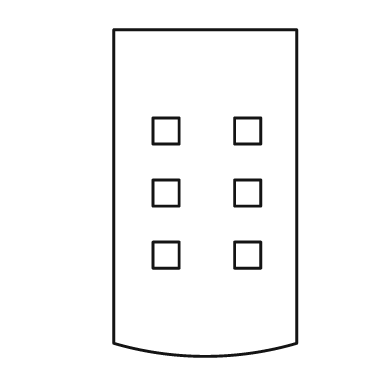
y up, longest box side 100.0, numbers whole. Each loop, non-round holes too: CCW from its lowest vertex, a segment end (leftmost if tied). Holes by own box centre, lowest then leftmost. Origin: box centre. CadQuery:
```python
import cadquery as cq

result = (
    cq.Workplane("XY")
    .moveTo(-28.0, -46.0)
    .threePointArc((0.0, -50.0), (28.0, -46.0))
    .lineTo(28.0, 50.0)
    .lineTo(-28.0, 50.0)
    .close()
    .moveTo(-16.0, -23.0)
    .lineTo(-8.0, -23.0)
    .lineTo(-8.0, -15.0)
    .lineTo(-16.0, -15.0)
    .close()
    .moveTo(9.0, -23.0)
    .lineTo(17.0, -23.0)
    .lineTo(17.0, -15.0)
    .lineTo(9.0, -15.0)
    .close()
    .moveTo(-16.0, -4.0)
    .lineTo(-8.0, -4.0)
    .lineTo(-8.0, 4.0)
    .lineTo(-16.0, 4.0)
    .close()
    .moveTo(9.0, -4.0)
    .lineTo(17.0, -4.0)
    .lineTo(17.0, 4.0)
    .lineTo(9.0, 4.0)
    .close()
    .moveTo(-16.0, 15.0)
    .lineTo(-8.0, 15.0)
    .lineTo(-8.0, 23.0)
    .lineTo(-16.0, 23.0)
    .close()
    .moveTo(9.0, 15.0)
    .lineTo(17.0, 15.0)
    .lineTo(17.0, 23.0)
    .lineTo(9.0, 23.0)
    .close()
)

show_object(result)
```